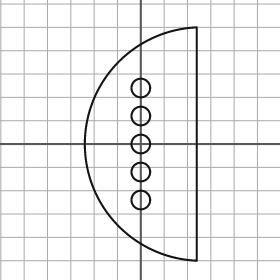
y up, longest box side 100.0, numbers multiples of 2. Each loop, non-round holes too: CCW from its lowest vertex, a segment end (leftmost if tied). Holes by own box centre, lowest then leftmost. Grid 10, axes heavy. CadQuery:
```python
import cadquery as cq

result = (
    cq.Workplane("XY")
    .moveTo(24.0, -50.0)
    .lineTo(24.0, 50.0)
    .threePointArc((-24.0, 0.0), (24.0, -50.0))
    .close()
    .moveTo(0.0, -24.0)
    .circle(4.0)
    .moveTo(0.0, -12.0)
    .circle(4.0)
    .moveTo(0.0, 0.0)
    .circle(4.0)
    .moveTo(0.0, 12.0)
    .circle(4.0)
    .moveTo(0.0, 24.0)
    .circle(4.0)
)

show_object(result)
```